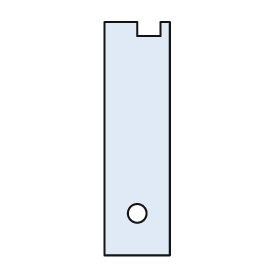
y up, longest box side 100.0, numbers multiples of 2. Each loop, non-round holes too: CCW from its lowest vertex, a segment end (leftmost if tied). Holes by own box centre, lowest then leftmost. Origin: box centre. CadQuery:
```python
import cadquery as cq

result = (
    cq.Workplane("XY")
    .moveTo(-14.0, -50.0)
    .lineTo(14.0, -50.0)
    .lineTo(14.0, 50.0)
    .lineTo(10.0, 50.0)
    .lineTo(10.0, 44.0)
    .lineTo(0.0, 44.0)
    .lineTo(0.0, 50.0)
    .lineTo(-14.0, 50.0)
    .close()
    .moveTo(0.0, -32.0)
    .circle(4.0)
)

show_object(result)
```